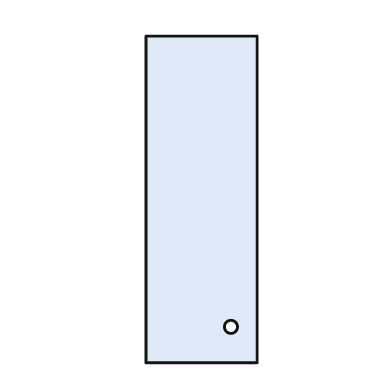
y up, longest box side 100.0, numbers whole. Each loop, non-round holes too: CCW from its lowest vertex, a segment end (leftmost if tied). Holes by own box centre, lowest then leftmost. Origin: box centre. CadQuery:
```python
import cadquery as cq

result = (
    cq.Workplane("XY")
    .moveTo(-17.0, -50.0)
    .lineTo(17.0, -50.0)
    .lineTo(17.0, 50.0)
    .lineTo(-17.0, 50.0)
    .close()
    .moveTo(9.0, -39.0)
    .circle(2.0)
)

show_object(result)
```